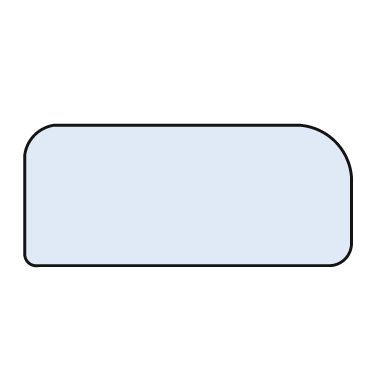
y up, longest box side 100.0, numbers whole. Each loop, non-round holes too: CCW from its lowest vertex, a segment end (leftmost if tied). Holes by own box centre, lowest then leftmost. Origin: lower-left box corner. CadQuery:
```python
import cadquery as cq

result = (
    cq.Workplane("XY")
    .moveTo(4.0, 0.0)
    .lineTo(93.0, 0.0)
    .threePointArc((98.0, 2.0), (100.0, 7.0))
    .lineTo(100.0, 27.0)
    .threePointArc((95.0, 38.0), (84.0, 43.0))
    .lineTo(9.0, 43.0)
    .threePointArc((3.0, 40.0), (0.0, 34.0))
    .lineTo(0.0, 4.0)
    .threePointArc((1.0, 1.0), (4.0, 0.0))
    .close()
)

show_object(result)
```